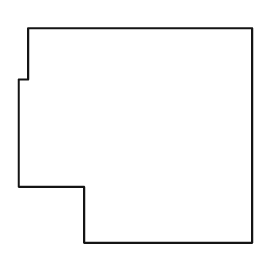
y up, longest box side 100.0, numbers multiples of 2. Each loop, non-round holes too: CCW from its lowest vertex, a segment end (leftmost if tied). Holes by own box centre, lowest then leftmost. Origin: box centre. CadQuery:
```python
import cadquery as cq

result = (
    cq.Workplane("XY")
    .moveTo(-22.0, -46.0)
    .lineTo(50.0, -46.0)
    .lineTo(50.0, 46.0)
    .lineTo(-46.0, 46.0)
    .lineTo(-46.0, 24.0)
    .lineTo(-50.0, 24.0)
    .lineTo(-50.0, -22.0)
    .lineTo(-22.0, -22.0)
    .close()
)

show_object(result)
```